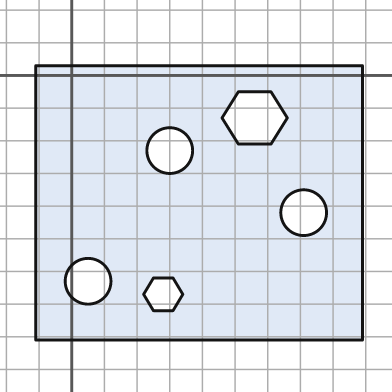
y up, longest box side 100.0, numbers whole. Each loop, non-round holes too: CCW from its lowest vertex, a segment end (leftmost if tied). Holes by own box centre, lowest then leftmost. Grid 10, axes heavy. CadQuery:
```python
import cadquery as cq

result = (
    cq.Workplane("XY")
    .moveTo(-11.0, -81.0)
    .lineTo(89.0, -81.0)
    .lineTo(89.0, 3.0)
    .lineTo(-11.0, 3.0)
    .close()
    .moveTo(25.0, -72.0)
    .lineTo(31.0, -72.0)
    .lineTo(34.0, -67.0)
    .lineTo(31.0, -62.0)
    .lineTo(25.0, -62.0)
    .lineTo(22.0, -67.0)
    .close()
    .moveTo(5.0, -63.0)
    .circle(7.0)
    .moveTo(71.0, -42.0)
    .circle(7.0)
    .moveTo(30.0, -23.0)
    .circle(7.0)
    .moveTo(51.0, -21.0)
    .lineTo(61.0, -21.0)
    .lineTo(66.0, -13.0)
    .lineTo(61.0, -5.0)
    .lineTo(51.0, -5.0)
    .lineTo(46.0, -13.0)
    .close()
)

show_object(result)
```